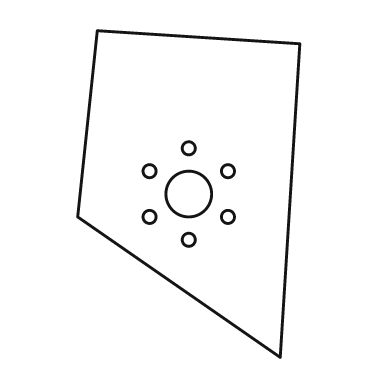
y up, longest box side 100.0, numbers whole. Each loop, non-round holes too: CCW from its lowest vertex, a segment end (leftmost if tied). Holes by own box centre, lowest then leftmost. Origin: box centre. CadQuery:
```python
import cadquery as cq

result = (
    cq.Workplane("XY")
    .moveTo(28.0, -50.0)
    .lineTo(34.0, 46.0)
    .lineTo(-28.0, 50.0)
    .lineTo(-34.0, -7.0)
    .close()
    .moveTo(0.0, -14.0)
    .circle(2.0)
    .moveTo(-12.0, -7.0)
    .circle(2.0)
    .moveTo(12.0, -7.0)
    .circle(2.0)
    .moveTo(0.0, 0.0)
    .circle(7.0)
    .moveTo(-12.0, 7.0)
    .circle(2.0)
    .moveTo(12.0, 7.0)
    .circle(2.0)
    .moveTo(0.0, 14.0)
    .circle(2.0)
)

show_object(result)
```